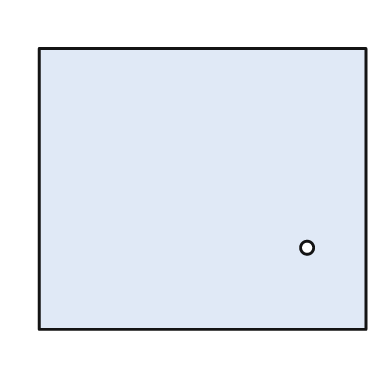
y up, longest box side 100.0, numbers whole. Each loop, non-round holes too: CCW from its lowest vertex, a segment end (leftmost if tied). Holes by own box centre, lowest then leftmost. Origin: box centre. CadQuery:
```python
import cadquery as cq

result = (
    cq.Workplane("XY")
    .moveTo(-50.0, -43.0)
    .lineTo(50.0, -43.0)
    .lineTo(50.0, 43.0)
    .lineTo(-50.0, 43.0)
    .close()
    .moveTo(32.0, -18.0)
    .circle(2.0)
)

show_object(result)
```